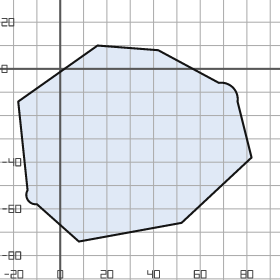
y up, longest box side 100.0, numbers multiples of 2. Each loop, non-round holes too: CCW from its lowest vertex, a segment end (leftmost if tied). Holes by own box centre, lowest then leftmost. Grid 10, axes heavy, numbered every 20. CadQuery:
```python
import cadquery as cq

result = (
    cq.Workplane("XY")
    .moveTo(8.0, -74.0)
    .lineTo(52.0, -66.0)
    .lineTo(82.0, -38.0)
    .lineTo(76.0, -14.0)
    .threePointArc((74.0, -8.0), (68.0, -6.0))
    .lineTo(42.0, 8.0)
    .lineTo(16.0, 10.0)
    .lineTo(-18.0, -14.0)
    .lineTo(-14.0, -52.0)
    .threePointArc((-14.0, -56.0), (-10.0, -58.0))
    .close()
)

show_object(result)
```